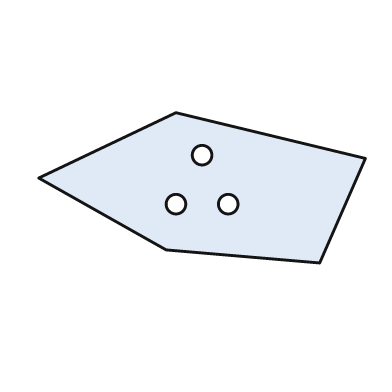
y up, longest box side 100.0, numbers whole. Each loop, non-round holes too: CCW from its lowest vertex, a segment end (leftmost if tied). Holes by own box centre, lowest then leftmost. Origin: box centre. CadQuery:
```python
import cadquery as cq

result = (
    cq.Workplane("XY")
    .moveTo(36.0, -23.0)
    .lineTo(50.0, 9.0)
    .lineTo(-8.0, 23.0)
    .lineTo(-50.0, 3.0)
    .lineTo(-11.0, -19.0)
    .close()
    .moveTo(-8.0, -5.0)
    .circle(3.0)
    .moveTo(8.0, -5.0)
    .circle(3.0)
    .moveTo(0.0, 10.0)
    .circle(3.0)
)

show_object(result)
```